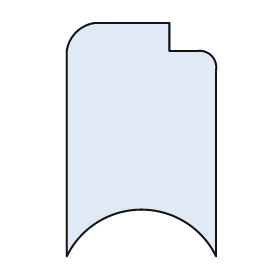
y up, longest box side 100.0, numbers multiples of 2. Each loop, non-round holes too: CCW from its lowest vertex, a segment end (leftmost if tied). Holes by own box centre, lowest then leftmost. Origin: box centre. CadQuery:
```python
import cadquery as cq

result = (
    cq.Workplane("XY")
    .moveTo(-32.0, -50.0)
    .threePointArc((0.0, -30.0), (32.0, -50.0))
    .lineTo(32.0, 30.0)
    .threePointArc((30.0, 36.0), (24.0, 38.0))
    .lineTo(12.0, 38.0)
    .lineTo(12.0, 50.0)
    .lineTo(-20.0, 50.0)
    .threePointArc((-28.0, 46.0), (-32.0, 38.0))
    .close()
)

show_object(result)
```